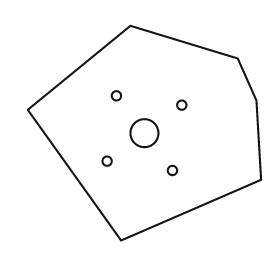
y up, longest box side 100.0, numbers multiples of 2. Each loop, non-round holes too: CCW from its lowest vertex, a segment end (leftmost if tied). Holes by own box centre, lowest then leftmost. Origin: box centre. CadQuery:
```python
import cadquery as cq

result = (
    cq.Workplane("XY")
    .moveTo(-10.0, -46.0)
    .lineTo(50.0, -20.0)
    .lineTo(48.0, 14.0)
    .lineTo(40.0, 32.0)
    .lineTo(-6.0, 46.0)
    .lineTo(-50.0, 10.0)
    .close()
    .moveTo(12.0, -16.0)
    .circle(2.0)
    .moveTo(-16.0, -12.0)
    .circle(2.0)
    .moveTo(0.0, 0.0)
    .circle(6.0)
    .moveTo(16.0, 12.0)
    .circle(2.0)
    .moveTo(-12.0, 16.0)
    .circle(2.0)
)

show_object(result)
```